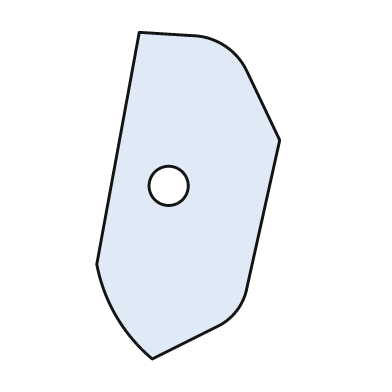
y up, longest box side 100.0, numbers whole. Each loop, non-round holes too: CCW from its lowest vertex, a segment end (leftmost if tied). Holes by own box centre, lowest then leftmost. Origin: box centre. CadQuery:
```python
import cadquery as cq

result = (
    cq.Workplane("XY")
    .moveTo(-11.0, -50.0)
    .lineTo(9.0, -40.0)
    .threePointArc((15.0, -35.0), (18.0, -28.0))
    .lineTo(28.0, 17.0)
    .lineTo(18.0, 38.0)
    .threePointArc((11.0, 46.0), (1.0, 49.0))
    .lineTo(-15.0, 50.0)
    .lineTo(-28.0, -21.0)
    .threePointArc((-22.0, -37.0), (-11.0, -50.0))
    .close()
    .moveTo(-6.0, 3.0)
    .circle(6.0)
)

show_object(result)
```